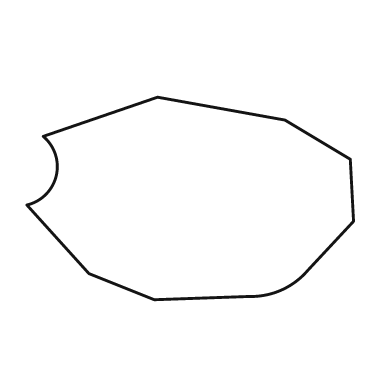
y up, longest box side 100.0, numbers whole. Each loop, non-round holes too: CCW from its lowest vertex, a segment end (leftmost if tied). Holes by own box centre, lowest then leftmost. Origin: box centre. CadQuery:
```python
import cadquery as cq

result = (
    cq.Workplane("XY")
    .moveTo(-11.0, -31.0)
    .lineTo(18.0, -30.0)
    .threePointArc((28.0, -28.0), (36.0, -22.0))
    .lineTo(50.0, -7.0)
    .lineTo(49.0, 12.0)
    .lineTo(29.0, 24.0)
    .lineTo(-10.0, 31.0)
    .lineTo(-45.0, 19.0)
    .threePointArc((-41.0, 7.0), (-50.0, -2.0))
    .lineTo(-31.0, -23.0)
    .close()
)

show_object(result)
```